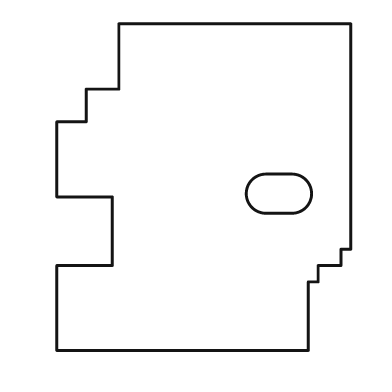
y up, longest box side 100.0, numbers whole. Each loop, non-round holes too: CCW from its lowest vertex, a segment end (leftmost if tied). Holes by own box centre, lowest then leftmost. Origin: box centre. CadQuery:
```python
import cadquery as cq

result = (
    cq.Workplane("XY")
    .moveTo(-45.0, -50.0)
    .lineTo(32.0, -50.0)
    .lineTo(32.0, -29.0)
    .lineTo(35.0, -29.0)
    .lineTo(35.0, -24.0)
    .lineTo(42.0, -24.0)
    .lineTo(42.0, -19.0)
    .lineTo(45.0, -19.0)
    .lineTo(45.0, 50.0)
    .lineTo(-26.0, 50.0)
    .lineTo(-26.0, 30.0)
    .lineTo(-36.0, 30.0)
    .lineTo(-36.0, 20.0)
    .lineTo(-45.0, 20.0)
    .lineTo(-45.0, -3.0)
    .lineTo(-28.0, -3.0)
    .lineTo(-28.0, -24.0)
    .lineTo(-45.0, -24.0)
    .close()
    .moveTo(19.0, -8.0)
    .lineTo(27.0, -8.0)
    .threePointArc((33.0, -2.0), (27.0, 4.0))
    .lineTo(19.0, 4.0)
    .threePointArc((13.0, -2.0), (19.0, -8.0))
    .close()
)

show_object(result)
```